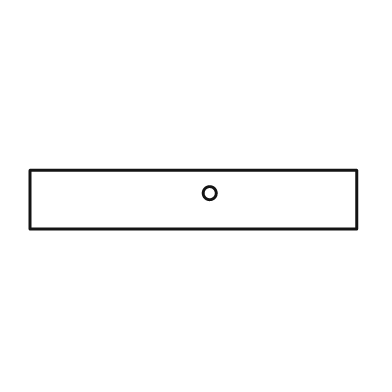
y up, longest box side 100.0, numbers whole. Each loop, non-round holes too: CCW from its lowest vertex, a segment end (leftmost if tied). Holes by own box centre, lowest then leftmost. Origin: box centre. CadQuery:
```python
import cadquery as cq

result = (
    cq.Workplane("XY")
    .moveTo(-50.0, -9.0)
    .lineTo(50.0, -9.0)
    .lineTo(50.0, 9.0)
    .lineTo(-50.0, 9.0)
    .close()
    .moveTo(5.0, 2.0)
    .circle(2.0)
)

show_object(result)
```